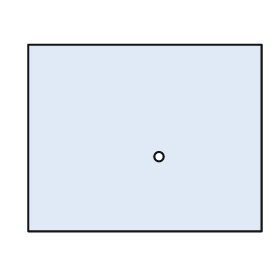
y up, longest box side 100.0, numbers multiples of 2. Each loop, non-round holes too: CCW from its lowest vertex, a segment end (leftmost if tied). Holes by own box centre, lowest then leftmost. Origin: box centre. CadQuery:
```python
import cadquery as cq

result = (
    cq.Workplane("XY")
    .moveTo(-50.0, -40.0)
    .lineTo(50.0, -40.0)
    .lineTo(50.0, 40.0)
    .lineTo(-50.0, 40.0)
    .close()
    .moveTo(6.0, -8.0)
    .circle(2.0)
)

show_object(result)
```